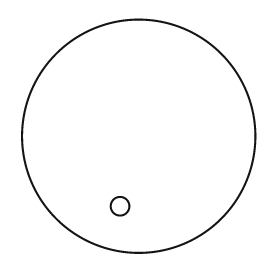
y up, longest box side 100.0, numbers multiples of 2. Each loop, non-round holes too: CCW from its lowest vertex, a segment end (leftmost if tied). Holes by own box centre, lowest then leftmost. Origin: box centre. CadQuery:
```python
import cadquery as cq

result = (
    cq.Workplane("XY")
    .moveTo(0.0, 0.0)
    .circle(50.0)
    .moveTo(-8.0, -30.0)
    .circle(4.0)
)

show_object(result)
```